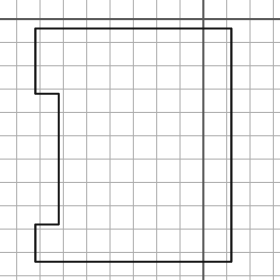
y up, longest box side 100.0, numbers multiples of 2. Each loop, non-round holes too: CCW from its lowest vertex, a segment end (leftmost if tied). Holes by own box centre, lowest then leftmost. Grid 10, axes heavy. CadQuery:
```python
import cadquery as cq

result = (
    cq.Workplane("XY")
    .moveTo(-72.0, -104.0)
    .lineTo(12.0, -104.0)
    .lineTo(12.0, -4.0)
    .lineTo(-72.0, -4.0)
    .lineTo(-72.0, -32.0)
    .lineTo(-62.0, -32.0)
    .lineTo(-62.0, -88.0)
    .lineTo(-72.0, -88.0)
    .close()
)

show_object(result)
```